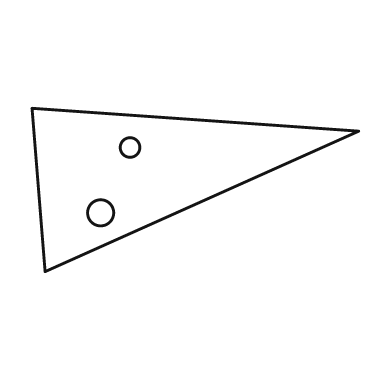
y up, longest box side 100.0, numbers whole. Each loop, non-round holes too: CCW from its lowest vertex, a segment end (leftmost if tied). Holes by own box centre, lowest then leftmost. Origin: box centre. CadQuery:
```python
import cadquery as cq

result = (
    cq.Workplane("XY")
    .moveTo(-46.0, -25.0)
    .lineTo(50.0, 18.0)
    .lineTo(-50.0, 25.0)
    .close()
    .moveTo(-29.0, -7.0)
    .circle(4.0)
    .moveTo(-20.0, 13.0)
    .circle(3.0)
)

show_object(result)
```